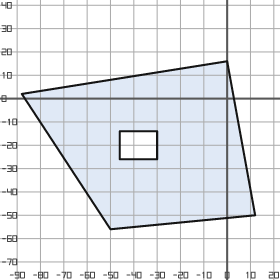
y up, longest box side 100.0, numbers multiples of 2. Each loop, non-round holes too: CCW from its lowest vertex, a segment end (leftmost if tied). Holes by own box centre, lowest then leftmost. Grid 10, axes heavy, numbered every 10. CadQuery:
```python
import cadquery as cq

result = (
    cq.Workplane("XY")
    .moveTo(-50.0, -56.0)
    .lineTo(12.0, -50.0)
    .lineTo(0.0, 16.0)
    .lineTo(-88.0, 2.0)
    .close()
    .moveTo(-46.0, -26.0)
    .lineTo(-30.0, -26.0)
    .lineTo(-30.0, -14.0)
    .lineTo(-46.0, -14.0)
    .close()
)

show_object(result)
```